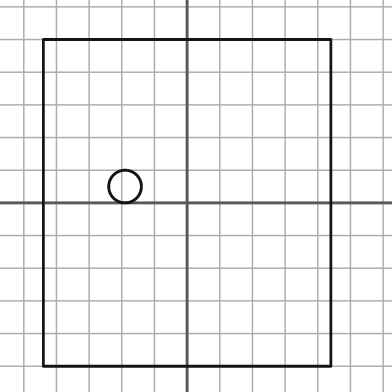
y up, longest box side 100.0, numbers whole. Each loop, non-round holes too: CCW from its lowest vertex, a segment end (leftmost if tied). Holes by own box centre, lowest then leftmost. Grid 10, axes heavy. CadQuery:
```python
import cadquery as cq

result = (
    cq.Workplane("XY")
    .moveTo(-44.0, -50.0)
    .lineTo(44.0, -50.0)
    .lineTo(44.0, 50.0)
    .lineTo(-44.0, 50.0)
    .close()
    .moveTo(-19.0, 5.0)
    .circle(5.0)
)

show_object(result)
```